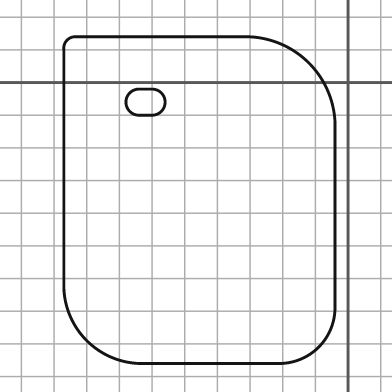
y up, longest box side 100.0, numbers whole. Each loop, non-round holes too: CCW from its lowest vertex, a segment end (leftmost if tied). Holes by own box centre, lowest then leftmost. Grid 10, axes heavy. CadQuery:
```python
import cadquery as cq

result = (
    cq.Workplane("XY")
    .moveTo(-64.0, -86.0)
    .lineTo(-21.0, -86.0)
    .threePointArc((-9.0, -81.0), (-4.0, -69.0))
    .lineTo(-4.0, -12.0)
    .threePointArc((-12.0, 6.0), (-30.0, 14.0))
    .lineTo(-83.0, 14.0)
    .threePointArc((-86.0, 13.0), (-87.0, 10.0))
    .lineTo(-87.0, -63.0)
    .threePointArc((-80.0, -79.0), (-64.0, -86.0))
    .close()
    .moveTo(-64.0, -10.0)
    .lineTo(-60.0, -10.0)
    .threePointArc((-56.0, -6.0), (-60.0, -2.0))
    .lineTo(-64.0, -2.0)
    .threePointArc((-68.0, -6.0), (-64.0, -10.0))
    .close()
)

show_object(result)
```